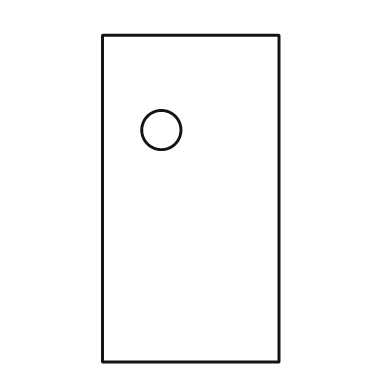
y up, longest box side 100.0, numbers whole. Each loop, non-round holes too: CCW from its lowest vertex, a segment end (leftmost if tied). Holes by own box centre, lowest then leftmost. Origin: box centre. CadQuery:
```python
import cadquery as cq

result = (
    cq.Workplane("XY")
    .moveTo(-27.0, -50.0)
    .lineTo(27.0, -50.0)
    .lineTo(27.0, 50.0)
    .lineTo(-27.0, 50.0)
    .close()
    .moveTo(-9.0, 21.0)
    .circle(6.0)
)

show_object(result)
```